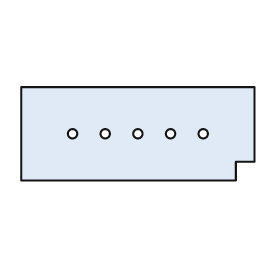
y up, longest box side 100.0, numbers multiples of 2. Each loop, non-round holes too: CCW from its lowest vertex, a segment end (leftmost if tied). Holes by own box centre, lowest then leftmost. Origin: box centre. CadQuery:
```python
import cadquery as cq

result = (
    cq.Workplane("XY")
    .moveTo(-50.0, -20.0)
    .lineTo(42.0, -20.0)
    .lineTo(42.0, -12.0)
    .lineTo(50.0, -12.0)
    .lineTo(50.0, 20.0)
    .lineTo(-50.0, 20.0)
    .close()
    .moveTo(-28.0, 0.0)
    .circle(2.0)
    .moveTo(-14.0, 0.0)
    .circle(2.0)
    .moveTo(0.0, 0.0)
    .circle(2.0)
    .moveTo(14.0, 0.0)
    .circle(2.0)
    .moveTo(28.0, 0.0)
    .circle(2.0)
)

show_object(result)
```